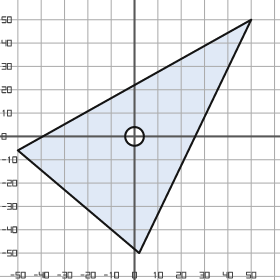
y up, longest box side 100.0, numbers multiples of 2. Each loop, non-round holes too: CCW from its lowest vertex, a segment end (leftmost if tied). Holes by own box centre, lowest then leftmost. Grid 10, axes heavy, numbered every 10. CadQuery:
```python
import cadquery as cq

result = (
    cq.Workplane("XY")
    .moveTo(2.0, -50.0)
    .lineTo(50.0, 50.0)
    .lineTo(-50.0, -6.0)
    .close()
    .moveTo(0.0, 0.0)
    .circle(4.0)
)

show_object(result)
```